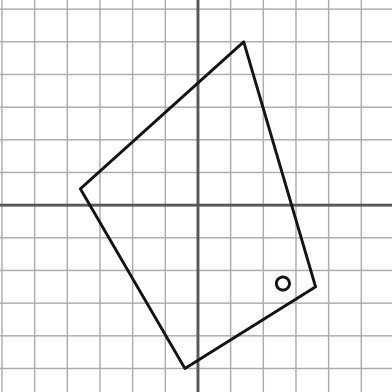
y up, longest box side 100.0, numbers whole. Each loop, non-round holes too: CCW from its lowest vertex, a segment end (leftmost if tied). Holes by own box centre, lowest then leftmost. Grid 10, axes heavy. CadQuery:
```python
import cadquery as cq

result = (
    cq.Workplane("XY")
    .moveTo(-4.0, -50.0)
    .lineTo(36.0, -25.0)
    .lineTo(14.0, 50.0)
    .lineTo(-36.0, 5.0)
    .close()
    .moveTo(26.0, -24.0)
    .circle(2.0)
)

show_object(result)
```